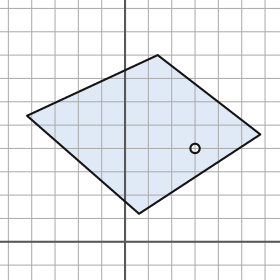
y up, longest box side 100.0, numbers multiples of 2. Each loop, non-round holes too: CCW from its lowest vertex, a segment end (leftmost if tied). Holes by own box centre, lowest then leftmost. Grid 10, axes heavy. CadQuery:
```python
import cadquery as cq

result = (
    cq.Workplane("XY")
    .moveTo(6.0, 12.0)
    .lineTo(58.0, 46.0)
    .lineTo(14.0, 80.0)
    .lineTo(-42.0, 54.0)
    .close()
    .moveTo(30.0, 40.0)
    .circle(2.0)
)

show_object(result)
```